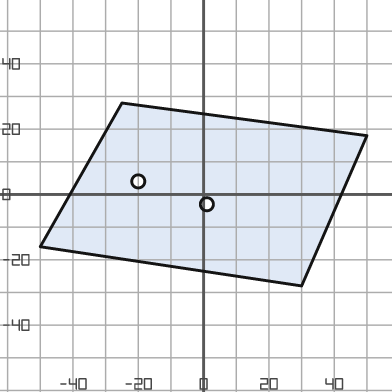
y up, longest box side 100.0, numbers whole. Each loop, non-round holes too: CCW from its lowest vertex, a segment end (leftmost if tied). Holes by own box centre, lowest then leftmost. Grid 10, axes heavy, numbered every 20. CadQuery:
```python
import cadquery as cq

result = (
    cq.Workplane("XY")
    .moveTo(30.0, -28.0)
    .lineTo(50.0, 18.0)
    .lineTo(-25.0, 28.0)
    .lineTo(-50.0, -16.0)
    .close()
    .moveTo(1.0, -3.0)
    .circle(2.0)
    .moveTo(-20.0, 4.0)
    .circle(2.0)
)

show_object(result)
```